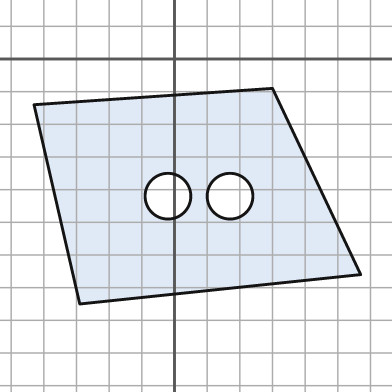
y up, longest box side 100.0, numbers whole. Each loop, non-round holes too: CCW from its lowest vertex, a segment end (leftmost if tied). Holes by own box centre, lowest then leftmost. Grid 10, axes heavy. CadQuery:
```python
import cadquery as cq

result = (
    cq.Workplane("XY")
    .moveTo(-29.0, -75.0)
    .lineTo(57.0, -66.0)
    .lineTo(30.0, -9.0)
    .lineTo(-43.0, -14.0)
    .close()
    .moveTo(-2.0, -42.0)
    .circle(7.0)
    .moveTo(17.0, -42.0)
    .circle(7.0)
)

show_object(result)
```